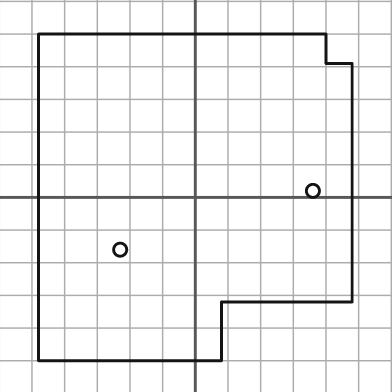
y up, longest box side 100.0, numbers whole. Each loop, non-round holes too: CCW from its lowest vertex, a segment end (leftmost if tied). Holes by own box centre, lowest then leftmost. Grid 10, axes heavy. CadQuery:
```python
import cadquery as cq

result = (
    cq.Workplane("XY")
    .moveTo(-48.0, -50.0)
    .lineTo(8.0, -50.0)
    .lineTo(8.0, -32.0)
    .lineTo(48.0, -32.0)
    .lineTo(48.0, 41.0)
    .lineTo(40.0, 41.0)
    .lineTo(40.0, 50.0)
    .lineTo(-48.0, 50.0)
    .close()
    .moveTo(-23.0, -16.0)
    .circle(2.0)
    .moveTo(36.0, 2.0)
    .circle(2.0)
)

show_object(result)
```